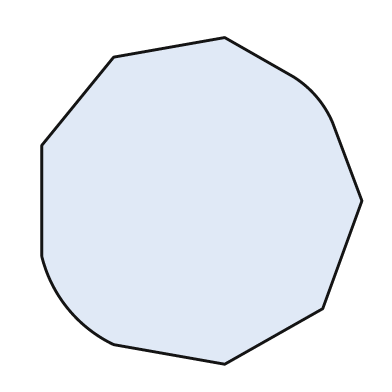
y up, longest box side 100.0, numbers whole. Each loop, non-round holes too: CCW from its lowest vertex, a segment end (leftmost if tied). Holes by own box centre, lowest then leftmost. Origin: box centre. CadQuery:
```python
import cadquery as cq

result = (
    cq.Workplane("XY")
    .moveTo(7.0, -50.0)
    .lineTo(37.0, -33.0)
    .lineTo(49.0, 0.0)
    .lineTo(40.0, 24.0)
    .threePointArc((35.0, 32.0), (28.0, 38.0))
    .lineTo(7.0, 50.0)
    .lineTo(-27.0, 44.0)
    .lineTo(-49.0, 17.0)
    .lineTo(-49.0, -17.0)
    .threePointArc((-41.0, -33.0), (-27.0, -44.0))
    .close()
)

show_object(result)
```